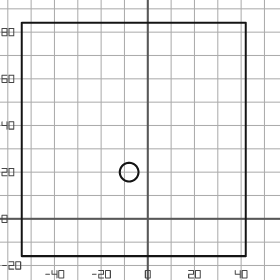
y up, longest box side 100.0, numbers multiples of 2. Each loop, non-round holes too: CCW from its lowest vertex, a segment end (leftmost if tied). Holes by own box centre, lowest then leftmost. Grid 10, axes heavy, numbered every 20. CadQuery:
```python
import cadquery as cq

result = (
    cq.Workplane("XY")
    .moveTo(-54.0, -16.0)
    .lineTo(42.0, -16.0)
    .lineTo(42.0, 84.0)
    .lineTo(-54.0, 84.0)
    .close()
    .moveTo(-8.0, 20.0)
    .circle(4.0)
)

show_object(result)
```